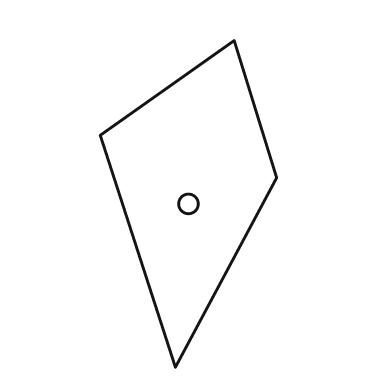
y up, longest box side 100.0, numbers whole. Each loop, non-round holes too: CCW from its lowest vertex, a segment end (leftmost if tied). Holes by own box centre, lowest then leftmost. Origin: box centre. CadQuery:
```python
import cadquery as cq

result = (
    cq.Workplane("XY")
    .moveTo(-4.0, -50.0)
    .lineTo(27.0, 8.0)
    .lineTo(14.0, 50.0)
    .lineTo(-27.0, 21.0)
    .close()
    .moveTo(0.0, 0.0)
    .circle(3.0)
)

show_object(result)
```